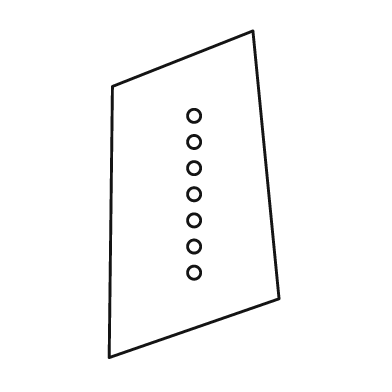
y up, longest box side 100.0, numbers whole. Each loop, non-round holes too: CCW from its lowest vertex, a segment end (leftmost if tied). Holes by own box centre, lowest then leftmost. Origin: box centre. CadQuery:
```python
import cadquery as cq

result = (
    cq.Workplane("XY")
    .moveTo(-26.0, -50.0)
    .lineTo(26.0, -32.0)
    .lineTo(18.0, 50.0)
    .lineTo(-25.0, 33.0)
    .close()
    .moveTo(0.0, -24.0)
    .circle(2.0)
    .moveTo(0.0, -16.0)
    .circle(2.0)
    .moveTo(0.0, -8.0)
    .circle(2.0)
    .moveTo(0.0, 0.0)
    .circle(2.0)
    .moveTo(0.0, 8.0)
    .circle(2.0)
    .moveTo(0.0, 16.0)
    .circle(2.0)
    .moveTo(0.0, 24.0)
    .circle(2.0)
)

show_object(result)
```